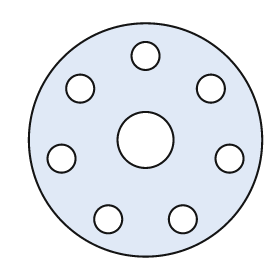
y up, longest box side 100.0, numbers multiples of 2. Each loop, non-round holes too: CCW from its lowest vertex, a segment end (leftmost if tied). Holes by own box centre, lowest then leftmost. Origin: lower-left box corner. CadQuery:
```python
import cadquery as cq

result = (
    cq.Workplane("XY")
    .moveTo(50.0, 50.0)
    .circle(50.0)
    .moveTo(34.0, 16.0)
    .circle(6.0)
    .moveTo(66.0, 16.0)
    .circle(6.0)
    .moveTo(14.0, 42.0)
    .circle(6.0)
    .moveTo(86.0, 42.0)
    .circle(6.0)
    .moveTo(50.0, 50.0)
    .circle(12.0)
    .moveTo(22.0, 72.0)
    .circle(6.0)
    .moveTo(78.0, 72.0)
    .circle(6.0)
    .moveTo(50.0, 86.0)
    .circle(6.0)
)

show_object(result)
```